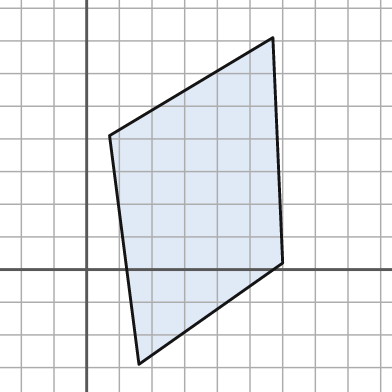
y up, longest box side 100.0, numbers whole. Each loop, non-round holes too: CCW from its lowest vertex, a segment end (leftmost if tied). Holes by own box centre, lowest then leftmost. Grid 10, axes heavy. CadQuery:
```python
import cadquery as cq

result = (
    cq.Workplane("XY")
    .moveTo(16.0, -29.0)
    .lineTo(60.0, 2.0)
    .lineTo(57.0, 71.0)
    .lineTo(7.0, 41.0)
    .close()
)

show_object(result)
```